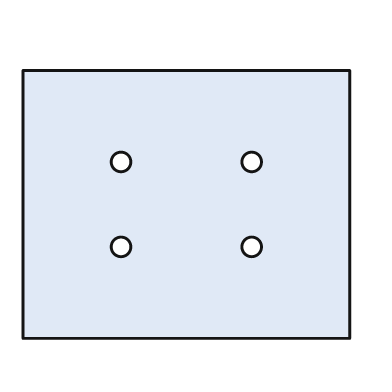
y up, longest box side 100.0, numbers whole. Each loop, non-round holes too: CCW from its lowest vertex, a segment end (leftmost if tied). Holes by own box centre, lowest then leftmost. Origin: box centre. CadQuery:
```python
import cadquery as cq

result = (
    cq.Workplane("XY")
    .moveTo(-50.0, -41.0)
    .lineTo(50.0, -41.0)
    .lineTo(50.0, 41.0)
    .lineTo(-50.0, 41.0)
    .close()
    .moveTo(-20.0, -13.0)
    .circle(3.0)
    .moveTo(20.0, -13.0)
    .circle(3.0)
    .moveTo(-20.0, 13.0)
    .circle(3.0)
    .moveTo(20.0, 13.0)
    .circle(3.0)
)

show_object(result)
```